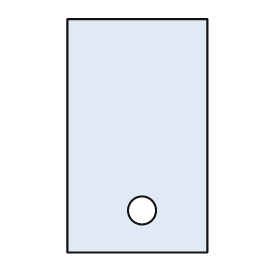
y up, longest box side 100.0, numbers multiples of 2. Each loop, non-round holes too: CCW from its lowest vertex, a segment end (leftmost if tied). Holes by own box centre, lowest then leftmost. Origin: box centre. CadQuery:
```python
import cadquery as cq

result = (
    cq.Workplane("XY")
    .moveTo(-30.0, -50.0)
    .lineTo(30.0, -50.0)
    .lineTo(30.0, 50.0)
    .lineTo(-30.0, 50.0)
    .close()
    .moveTo(2.0, -32.0)
    .circle(6.0)
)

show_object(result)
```